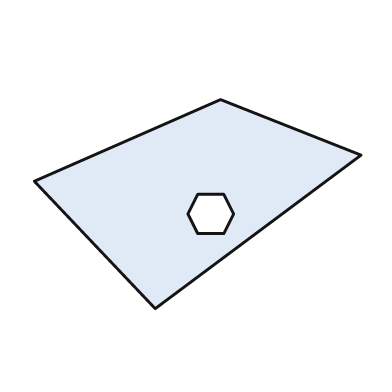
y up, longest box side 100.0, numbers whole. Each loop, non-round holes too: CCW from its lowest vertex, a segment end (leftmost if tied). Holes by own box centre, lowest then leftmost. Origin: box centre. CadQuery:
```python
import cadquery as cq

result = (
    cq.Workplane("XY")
    .moveTo(-13.0, -32.0)
    .lineTo(50.0, 15.0)
    .lineTo(7.0, 32.0)
    .lineTo(-50.0, 7.0)
    .close()
    .moveTo(0.0, -9.0)
    .lineTo(8.0, -9.0)
    .lineTo(11.0, -3.0)
    .lineTo(8.0, 3.0)
    .lineTo(0.0, 3.0)
    .lineTo(-3.0, -3.0)
    .close()
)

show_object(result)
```